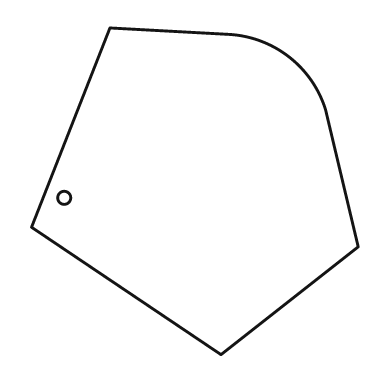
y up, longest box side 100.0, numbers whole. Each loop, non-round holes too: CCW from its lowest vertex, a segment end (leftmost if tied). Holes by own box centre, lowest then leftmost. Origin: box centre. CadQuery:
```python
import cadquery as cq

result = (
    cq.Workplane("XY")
    .moveTo(8.0, -50.0)
    .lineTo(50.0, -17.0)
    .lineTo(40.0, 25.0)
    .threePointArc((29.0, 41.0), (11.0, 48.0))
    .lineTo(-26.0, 50.0)
    .lineTo(-50.0, -11.0)
    .close()
    .moveTo(-40.0, -2.0)
    .circle(2.0)
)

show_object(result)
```